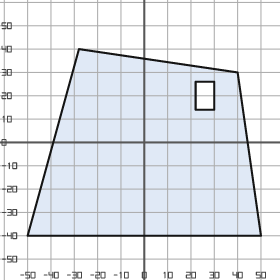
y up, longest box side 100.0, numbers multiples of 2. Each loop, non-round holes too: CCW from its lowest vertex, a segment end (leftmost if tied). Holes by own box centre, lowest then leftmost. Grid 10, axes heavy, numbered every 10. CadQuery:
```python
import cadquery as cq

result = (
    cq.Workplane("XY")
    .moveTo(-50.0, -40.0)
    .lineTo(50.0, -40.0)
    .lineTo(40.0, 30.0)
    .lineTo(-28.0, 40.0)
    .close()
    .moveTo(22.0, 14.0)
    .lineTo(30.0, 14.0)
    .lineTo(30.0, 26.0)
    .lineTo(22.0, 26.0)
    .close()
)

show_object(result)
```